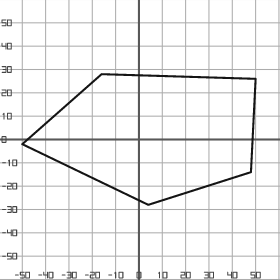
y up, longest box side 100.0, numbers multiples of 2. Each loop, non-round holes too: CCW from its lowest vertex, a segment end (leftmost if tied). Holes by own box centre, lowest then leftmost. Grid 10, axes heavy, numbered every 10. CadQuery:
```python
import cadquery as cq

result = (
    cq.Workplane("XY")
    .moveTo(4.0, -28.0)
    .lineTo(48.0, -14.0)
    .lineTo(50.0, 26.0)
    .lineTo(-16.0, 28.0)
    .lineTo(-50.0, -2.0)
    .close()
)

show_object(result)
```